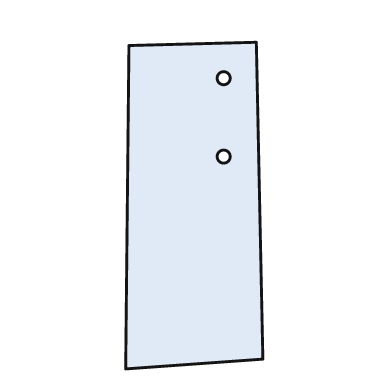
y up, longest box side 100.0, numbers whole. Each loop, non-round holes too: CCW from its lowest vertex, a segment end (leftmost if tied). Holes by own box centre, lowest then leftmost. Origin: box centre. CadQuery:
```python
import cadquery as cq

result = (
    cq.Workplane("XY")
    .moveTo(-21.0, -50.0)
    .lineTo(21.0, -47.0)
    .lineTo(19.0, 50.0)
    .lineTo(-20.0, 49.0)
    .close()
    .moveTo(9.0, 15.0)
    .circle(2.0)
    .moveTo(9.0, 39.0)
    .circle(2.0)
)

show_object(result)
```